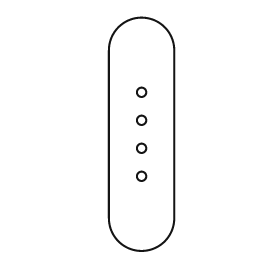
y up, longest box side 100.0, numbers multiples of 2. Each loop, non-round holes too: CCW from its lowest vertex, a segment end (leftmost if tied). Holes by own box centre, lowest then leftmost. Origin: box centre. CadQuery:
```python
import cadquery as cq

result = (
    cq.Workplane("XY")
    .moveTo(-14.0, -36.0)
    .threePointArc((0.0, -50.0), (14.0, -36.0))
    .lineTo(14.0, 36.0)
    .threePointArc((0.0, 50.0), (-14.0, 36.0))
    .close()
    .moveTo(0.0, -18.0)
    .circle(2.0)
    .moveTo(0.0, -6.0)
    .circle(2.0)
    .moveTo(0.0, 6.0)
    .circle(2.0)
    .moveTo(0.0, 18.0)
    .circle(2.0)
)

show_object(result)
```